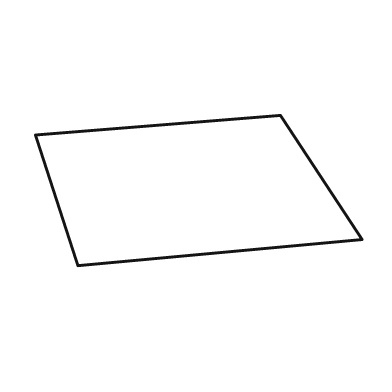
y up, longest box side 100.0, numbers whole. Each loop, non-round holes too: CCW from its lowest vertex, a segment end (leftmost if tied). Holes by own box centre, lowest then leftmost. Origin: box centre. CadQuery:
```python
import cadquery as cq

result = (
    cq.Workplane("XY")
    .moveTo(-37.0, -23.0)
    .lineTo(50.0, -15.0)
    .lineTo(25.0, 23.0)
    .lineTo(-50.0, 17.0)
    .close()
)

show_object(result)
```